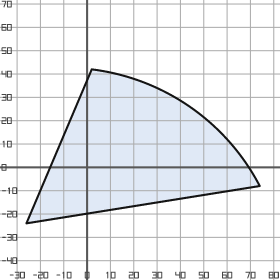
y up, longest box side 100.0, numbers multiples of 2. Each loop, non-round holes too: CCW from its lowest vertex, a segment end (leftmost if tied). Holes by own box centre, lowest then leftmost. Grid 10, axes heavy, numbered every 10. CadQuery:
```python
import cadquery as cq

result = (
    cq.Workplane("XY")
    .moveTo(-26.0, -24.0)
    .lineTo(74.0, -8.0)
    .threePointArc((44.0, 26.0), (2.0, 42.0))
    .close()
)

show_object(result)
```